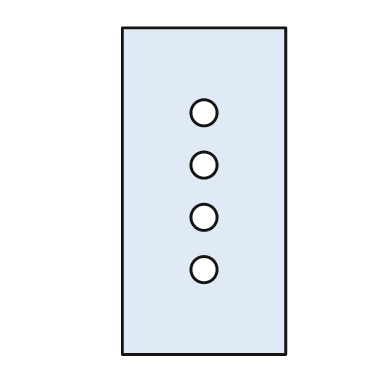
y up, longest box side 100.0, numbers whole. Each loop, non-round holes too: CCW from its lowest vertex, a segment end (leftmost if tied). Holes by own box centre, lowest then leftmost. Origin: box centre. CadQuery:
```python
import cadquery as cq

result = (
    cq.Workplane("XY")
    .moveTo(-25.0, -50.0)
    .lineTo(25.0, -50.0)
    .lineTo(25.0, 50.0)
    .lineTo(-25.0, 50.0)
    .close()
    .moveTo(0.0, -24.0)
    .circle(4.0)
    .moveTo(0.0, -8.0)
    .circle(4.0)
    .moveTo(0.0, 8.0)
    .circle(4.0)
    .moveTo(0.0, 24.0)
    .circle(4.0)
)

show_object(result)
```